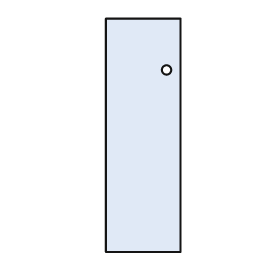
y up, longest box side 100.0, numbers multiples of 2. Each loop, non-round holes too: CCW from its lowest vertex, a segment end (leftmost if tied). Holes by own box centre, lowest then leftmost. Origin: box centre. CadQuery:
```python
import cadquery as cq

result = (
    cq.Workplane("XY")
    .moveTo(-16.0, -50.0)
    .lineTo(16.0, -50.0)
    .lineTo(16.0, 50.0)
    .lineTo(-16.0, 50.0)
    .close()
    .moveTo(10.0, 28.0)
    .circle(2.0)
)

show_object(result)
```